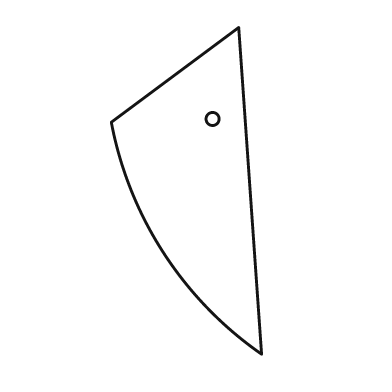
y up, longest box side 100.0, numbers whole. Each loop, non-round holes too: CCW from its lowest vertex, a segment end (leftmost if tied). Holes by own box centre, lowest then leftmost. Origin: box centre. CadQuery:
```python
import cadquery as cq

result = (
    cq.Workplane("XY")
    .moveTo(23.0, -50.0)
    .lineTo(16.0, 50.0)
    .lineTo(-23.0, 21.0)
    .threePointArc((-7.0, -19.0), (23.0, -50.0))
    .close()
    .moveTo(8.0, 22.0)
    .circle(2.0)
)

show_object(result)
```